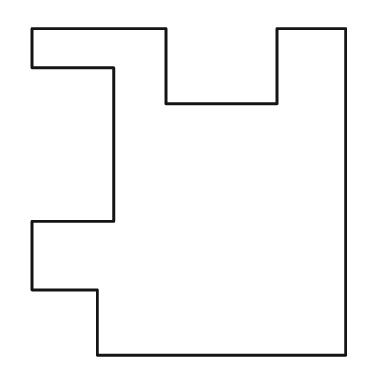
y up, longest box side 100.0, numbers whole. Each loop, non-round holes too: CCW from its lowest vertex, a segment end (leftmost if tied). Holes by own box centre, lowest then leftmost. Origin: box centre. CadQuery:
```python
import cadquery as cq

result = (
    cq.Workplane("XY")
    .moveTo(-28.0, -50.0)
    .lineTo(48.0, -50.0)
    .lineTo(48.0, 50.0)
    .lineTo(27.0, 50.0)
    .lineTo(27.0, 27.0)
    .lineTo(-7.0, 27.0)
    .lineTo(-7.0, 50.0)
    .lineTo(-48.0, 50.0)
    .lineTo(-48.0, 38.0)
    .lineTo(-23.0, 38.0)
    .lineTo(-23.0, -9.0)
    .lineTo(-48.0, -9.0)
    .lineTo(-48.0, -30.0)
    .lineTo(-28.0, -30.0)
    .close()
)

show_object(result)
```